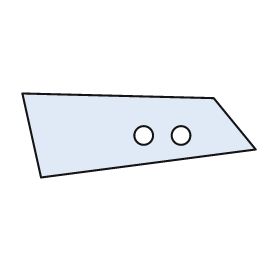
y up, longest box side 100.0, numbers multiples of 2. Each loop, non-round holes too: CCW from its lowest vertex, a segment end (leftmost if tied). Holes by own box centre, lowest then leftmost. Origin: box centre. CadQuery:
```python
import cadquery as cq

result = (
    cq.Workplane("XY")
    .moveTo(-42.0, -18.0)
    .lineTo(50.0, -6.0)
    .lineTo(32.0, 16.0)
    .lineTo(-50.0, 18.0)
    .close()
    .moveTo(2.0, 0.0)
    .circle(4.0)
    .moveTo(18.0, 0.0)
    .circle(4.0)
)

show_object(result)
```